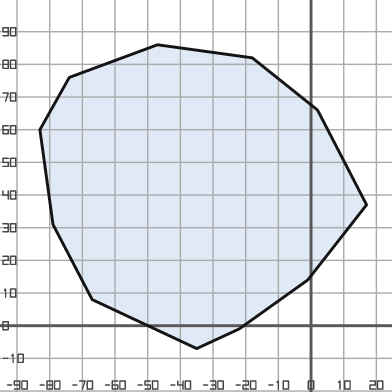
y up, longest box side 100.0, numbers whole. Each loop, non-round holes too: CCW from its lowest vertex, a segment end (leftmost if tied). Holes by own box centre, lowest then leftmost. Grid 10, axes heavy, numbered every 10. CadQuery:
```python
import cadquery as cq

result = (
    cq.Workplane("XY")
    .moveTo(-35.0, -7.0)
    .lineTo(-22.0, -1.0)
    .lineTo(-1.0, 14.0)
    .lineTo(17.0, 37.0)
    .lineTo(2.0, 66.0)
    .lineTo(-18.0, 82.0)
    .lineTo(-47.0, 86.0)
    .lineTo(-74.0, 76.0)
    .lineTo(-83.0, 60.0)
    .lineTo(-79.0, 31.0)
    .lineTo(-67.0, 8.0)
    .close()
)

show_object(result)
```